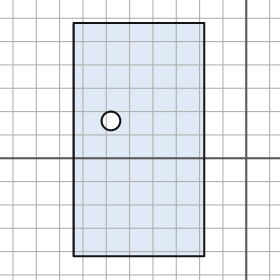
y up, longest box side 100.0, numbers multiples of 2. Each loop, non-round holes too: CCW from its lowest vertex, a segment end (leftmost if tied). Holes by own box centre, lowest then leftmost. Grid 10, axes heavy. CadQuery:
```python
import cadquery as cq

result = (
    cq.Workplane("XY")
    .moveTo(-74.0, -42.0)
    .lineTo(-18.0, -42.0)
    .lineTo(-18.0, 58.0)
    .lineTo(-74.0, 58.0)
    .close()
    .moveTo(-58.0, 16.0)
    .circle(4.0)
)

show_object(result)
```